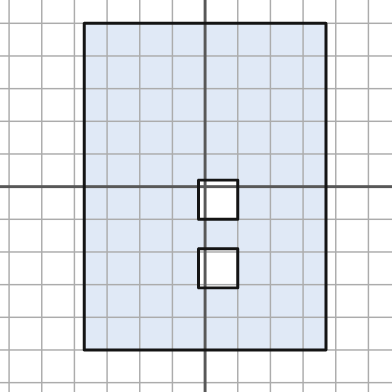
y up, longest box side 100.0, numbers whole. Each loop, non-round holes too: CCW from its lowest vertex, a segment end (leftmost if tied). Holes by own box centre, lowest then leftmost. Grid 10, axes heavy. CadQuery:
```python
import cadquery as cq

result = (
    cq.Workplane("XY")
    .moveTo(-37.0, -50.0)
    .lineTo(37.0, -50.0)
    .lineTo(37.0, 50.0)
    .lineTo(-37.0, 50.0)
    .close()
    .moveTo(-2.0, -31.0)
    .lineTo(10.0, -31.0)
    .lineTo(10.0, -19.0)
    .lineTo(-2.0, -19.0)
    .close()
    .moveTo(-2.0, -10.0)
    .lineTo(10.0, -10.0)
    .lineTo(10.0, 2.0)
    .lineTo(-2.0, 2.0)
    .close()
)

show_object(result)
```